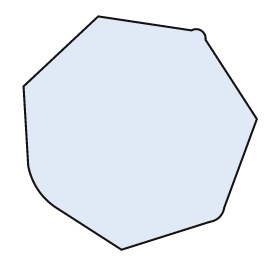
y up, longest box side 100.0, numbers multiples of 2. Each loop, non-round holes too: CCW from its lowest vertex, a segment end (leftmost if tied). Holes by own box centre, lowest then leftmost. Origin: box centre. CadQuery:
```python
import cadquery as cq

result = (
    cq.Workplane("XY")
    .moveTo(-8.0, -50.0)
    .lineTo(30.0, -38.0)
    .threePointArc((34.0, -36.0), (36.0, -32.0))
    .lineTo(50.0, 6.0)
    .lineTo(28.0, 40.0)
    .threePointArc((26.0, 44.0), (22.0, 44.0))
    .lineTo(-18.0, 50.0)
    .lineTo(-50.0, 20.0)
    .lineTo(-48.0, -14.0)
    .threePointArc((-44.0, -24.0), (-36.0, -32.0))
    .close()
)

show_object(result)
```